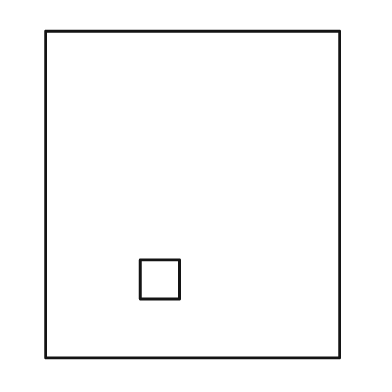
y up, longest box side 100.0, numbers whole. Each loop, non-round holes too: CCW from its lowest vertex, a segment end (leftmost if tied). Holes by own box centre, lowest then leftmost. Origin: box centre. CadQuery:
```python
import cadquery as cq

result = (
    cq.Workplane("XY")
    .moveTo(-45.0, -50.0)
    .lineTo(45.0, -50.0)
    .lineTo(45.0, 50.0)
    .lineTo(-45.0, 50.0)
    .close()
    .moveTo(-16.0, -32.0)
    .lineTo(-4.0, -32.0)
    .lineTo(-4.0, -20.0)
    .lineTo(-16.0, -20.0)
    .close()
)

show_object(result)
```